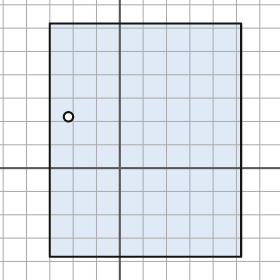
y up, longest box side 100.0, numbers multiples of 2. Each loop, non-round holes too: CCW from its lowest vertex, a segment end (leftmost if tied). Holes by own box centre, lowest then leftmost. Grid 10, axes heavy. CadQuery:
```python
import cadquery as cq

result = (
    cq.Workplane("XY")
    .moveTo(-30.0, -38.0)
    .lineTo(52.0, -38.0)
    .lineTo(52.0, 62.0)
    .lineTo(-30.0, 62.0)
    .close()
    .moveTo(-22.0, 22.0)
    .circle(2.0)
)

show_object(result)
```